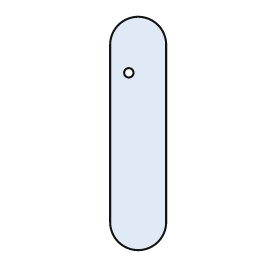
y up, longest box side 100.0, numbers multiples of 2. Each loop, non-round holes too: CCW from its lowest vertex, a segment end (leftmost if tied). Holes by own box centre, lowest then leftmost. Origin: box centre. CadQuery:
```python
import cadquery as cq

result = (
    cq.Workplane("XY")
    .moveTo(-12.0, -38.0)
    .threePointArc((0.0, -50.0), (12.0, -38.0))
    .lineTo(12.0, 38.0)
    .threePointArc((0.0, 50.0), (-12.0, 38.0))
    .close()
    .moveTo(-4.0, 26.0)
    .circle(2.0)
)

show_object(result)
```